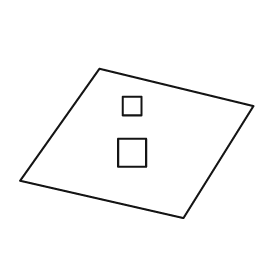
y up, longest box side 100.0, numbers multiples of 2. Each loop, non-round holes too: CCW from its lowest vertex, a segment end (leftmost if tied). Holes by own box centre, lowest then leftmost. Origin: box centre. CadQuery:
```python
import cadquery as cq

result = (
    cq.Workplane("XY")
    .moveTo(20.0, -32.0)
    .lineTo(50.0, 16.0)
    .lineTo(-16.0, 32.0)
    .lineTo(-50.0, -16.0)
    .close()
    .moveTo(-8.0, -10.0)
    .lineTo(4.0, -10.0)
    .lineTo(4.0, 2.0)
    .lineTo(-8.0, 2.0)
    .close()
    .moveTo(-6.0, 12.0)
    .lineTo(2.0, 12.0)
    .lineTo(2.0, 20.0)
    .lineTo(-6.0, 20.0)
    .close()
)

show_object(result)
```